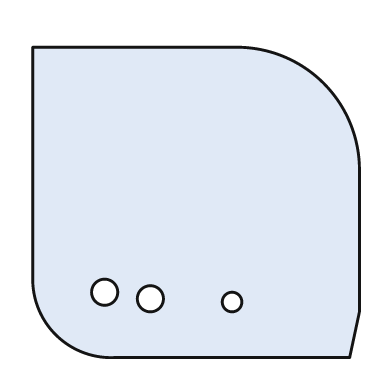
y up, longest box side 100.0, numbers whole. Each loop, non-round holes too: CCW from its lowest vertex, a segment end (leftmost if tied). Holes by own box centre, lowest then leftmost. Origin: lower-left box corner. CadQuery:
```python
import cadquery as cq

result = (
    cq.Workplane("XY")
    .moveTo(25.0, 0.0)
    .lineTo(97.0, 0.0)
    .lineTo(100.0, 14.0)
    .lineTo(100.0, 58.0)
    .threePointArc((89.0, 84.0), (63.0, 95.0))
    .lineTo(0.0, 95.0)
    .lineTo(0.0, 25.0)
    .threePointArc((7.0, 7.0), (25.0, 0.0))
    .close()
    .moveTo(61.0, 17.0)
    .circle(3.0)
    .moveTo(36.0, 18.0)
    .circle(4.0)
    .moveTo(22.0, 20.0)
    .circle(4.0)
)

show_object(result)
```